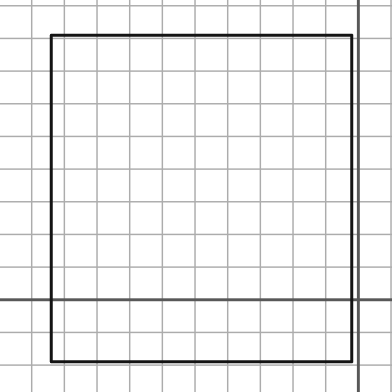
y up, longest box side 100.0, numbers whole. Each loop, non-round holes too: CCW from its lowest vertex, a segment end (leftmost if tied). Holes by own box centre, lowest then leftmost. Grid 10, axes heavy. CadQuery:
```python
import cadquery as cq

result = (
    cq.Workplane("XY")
    .moveTo(-94.0, -19.0)
    .lineTo(-2.0, -19.0)
    .lineTo(-2.0, 81.0)
    .lineTo(-94.0, 81.0)
    .close()
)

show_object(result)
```